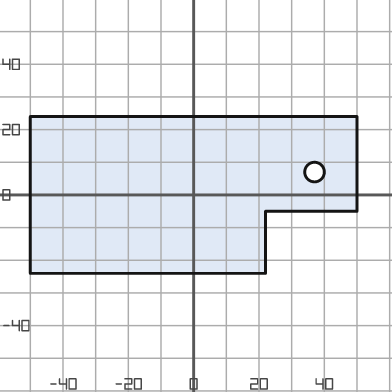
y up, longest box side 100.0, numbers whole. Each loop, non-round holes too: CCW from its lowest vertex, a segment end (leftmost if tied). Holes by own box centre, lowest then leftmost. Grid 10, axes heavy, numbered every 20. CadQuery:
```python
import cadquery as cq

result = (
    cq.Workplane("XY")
    .moveTo(-50.0, -24.0)
    .lineTo(22.0, -24.0)
    .lineTo(22.0, -5.0)
    .lineTo(50.0, -5.0)
    .lineTo(50.0, 24.0)
    .lineTo(-50.0, 24.0)
    .close()
    .moveTo(37.0, 7.0)
    .circle(3.0)
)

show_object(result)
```